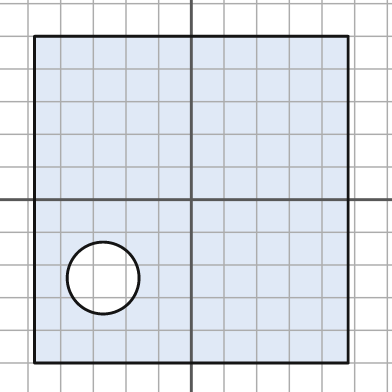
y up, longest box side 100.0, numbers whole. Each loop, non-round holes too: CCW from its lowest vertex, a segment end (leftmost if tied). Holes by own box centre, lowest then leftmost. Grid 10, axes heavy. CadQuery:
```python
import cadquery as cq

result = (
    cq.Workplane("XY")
    .moveTo(-48.0, -50.0)
    .lineTo(48.0, -50.0)
    .lineTo(48.0, 50.0)
    .lineTo(-48.0, 50.0)
    .close()
    .moveTo(-27.0, -24.0)
    .circle(11.0)
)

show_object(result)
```